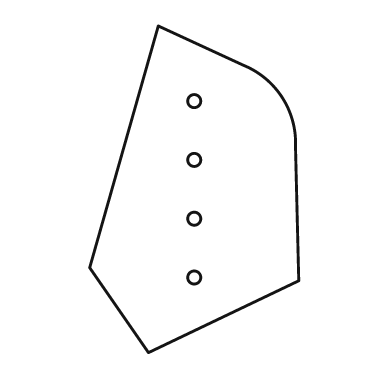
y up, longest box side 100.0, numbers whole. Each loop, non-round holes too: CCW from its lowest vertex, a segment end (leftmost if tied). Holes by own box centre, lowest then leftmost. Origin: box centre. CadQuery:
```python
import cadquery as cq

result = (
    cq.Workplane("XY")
    .moveTo(-14.0, -50.0)
    .lineTo(32.0, -28.0)
    .lineTo(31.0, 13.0)
    .threePointArc((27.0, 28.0), (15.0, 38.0))
    .lineTo(-11.0, 50.0)
    .lineTo(-32.0, -24.0)
    .close()
    .moveTo(0.0, -27.0)
    .circle(2.0)
    .moveTo(0.0, -9.0)
    .circle(2.0)
    .moveTo(0.0, 9.0)
    .circle(2.0)
    .moveTo(0.0, 27.0)
    .circle(2.0)
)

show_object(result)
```